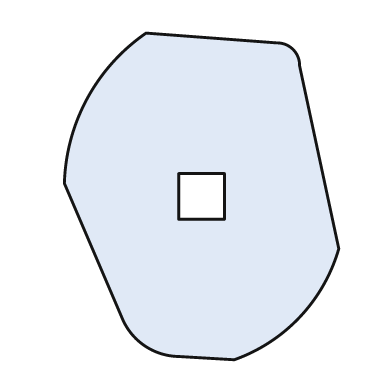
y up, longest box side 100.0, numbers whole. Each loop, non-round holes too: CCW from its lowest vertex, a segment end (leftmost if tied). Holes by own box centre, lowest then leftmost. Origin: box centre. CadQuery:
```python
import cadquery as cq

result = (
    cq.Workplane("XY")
    .moveTo(10.0, -50.0)
    .threePointArc((30.0, -37.0), (42.0, -16.0))
    .lineTo(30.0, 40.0)
    .threePointArc((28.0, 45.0), (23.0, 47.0))
    .lineTo(-17.0, 50.0)
    .threePointArc((-35.0, 30.0), (-42.0, 4.0))
    .lineTo(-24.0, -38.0)
    .threePointArc((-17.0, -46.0), (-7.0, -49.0))
    .close()
    .moveTo(-7.0, -7.0)
    .lineTo(7.0, -7.0)
    .lineTo(7.0, 7.0)
    .lineTo(-7.0, 7.0)
    .close()
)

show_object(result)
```